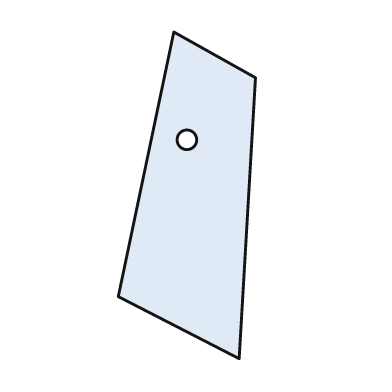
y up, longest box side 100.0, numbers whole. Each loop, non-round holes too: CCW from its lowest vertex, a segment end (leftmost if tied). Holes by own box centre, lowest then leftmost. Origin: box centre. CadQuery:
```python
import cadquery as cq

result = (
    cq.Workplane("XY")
    .moveTo(16.0, -50.0)
    .lineTo(21.0, 36.0)
    .lineTo(-4.0, 50.0)
    .lineTo(-21.0, -31.0)
    .close()
    .moveTo(0.0, 17.0)
    .circle(3.0)
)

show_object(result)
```